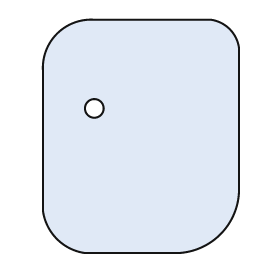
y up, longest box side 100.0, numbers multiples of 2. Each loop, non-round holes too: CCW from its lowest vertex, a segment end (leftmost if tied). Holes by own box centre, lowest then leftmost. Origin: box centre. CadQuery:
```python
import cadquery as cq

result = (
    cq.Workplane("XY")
    .moveTo(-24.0, -50.0)
    .lineTo(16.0, -50.0)
    .threePointArc((34.0, -42.0), (42.0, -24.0))
    .lineTo(42.0, 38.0)
    .threePointArc((38.0, 46.0), (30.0, 50.0))
    .lineTo(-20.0, 50.0)
    .threePointArc((-36.0, 44.0), (-42.0, 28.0))
    .lineTo(-42.0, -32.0)
    .threePointArc((-36.0, -44.0), (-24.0, -50.0))
    .close()
    .moveTo(-20.0, 12.0)
    .circle(4.0)
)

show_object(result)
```